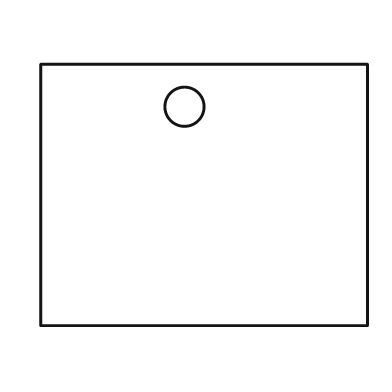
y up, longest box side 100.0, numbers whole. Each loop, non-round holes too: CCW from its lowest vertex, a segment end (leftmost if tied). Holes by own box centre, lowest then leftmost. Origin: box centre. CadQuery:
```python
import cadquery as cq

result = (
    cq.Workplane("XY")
    .moveTo(-50.0, -40.0)
    .lineTo(50.0, -40.0)
    .lineTo(50.0, 40.0)
    .lineTo(-50.0, 40.0)
    .close()
    .moveTo(-6.0, 27.0)
    .circle(6.0)
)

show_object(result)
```